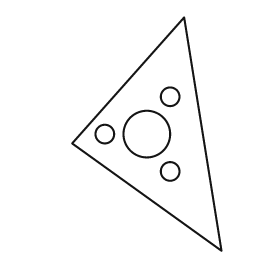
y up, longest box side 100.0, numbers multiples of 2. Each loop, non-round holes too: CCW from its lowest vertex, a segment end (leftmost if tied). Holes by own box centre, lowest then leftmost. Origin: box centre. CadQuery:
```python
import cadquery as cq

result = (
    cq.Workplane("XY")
    .moveTo(32.0, -50.0)
    .lineTo(16.0, 50.0)
    .lineTo(-32.0, -4.0)
    .close()
    .moveTo(10.0, -16.0)
    .circle(4.0)
    .moveTo(-18.0, 0.0)
    .circle(4.0)
    .moveTo(0.0, 0.0)
    .circle(10.0)
    .moveTo(10.0, 16.0)
    .circle(4.0)
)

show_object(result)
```